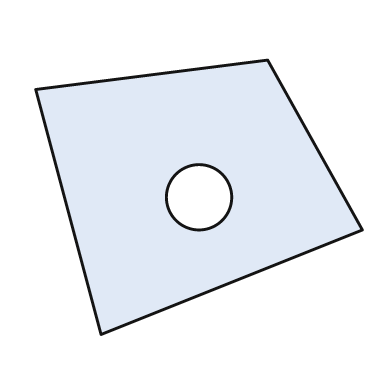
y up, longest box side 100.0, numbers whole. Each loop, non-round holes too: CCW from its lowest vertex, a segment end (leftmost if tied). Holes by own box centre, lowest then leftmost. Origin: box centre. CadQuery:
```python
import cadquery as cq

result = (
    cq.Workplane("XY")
    .moveTo(-30.0, -42.0)
    .lineTo(50.0, -10.0)
    .lineTo(21.0, 42.0)
    .lineTo(-50.0, 33.0)
    .close()
    .moveTo(0.0, 0.0)
    .circle(10.0)
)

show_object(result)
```